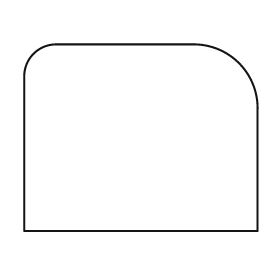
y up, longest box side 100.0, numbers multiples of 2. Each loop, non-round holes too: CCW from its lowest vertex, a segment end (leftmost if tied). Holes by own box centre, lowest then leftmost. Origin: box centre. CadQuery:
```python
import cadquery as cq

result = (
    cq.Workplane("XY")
    .moveTo(-50.0, -40.0)
    .lineTo(50.0, -40.0)
    .lineTo(50.0, 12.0)
    .threePointArc((42.0, 32.0), (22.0, 40.0))
    .lineTo(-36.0, 40.0)
    .threePointArc((-46.0, 36.0), (-50.0, 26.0))
    .close()
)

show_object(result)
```